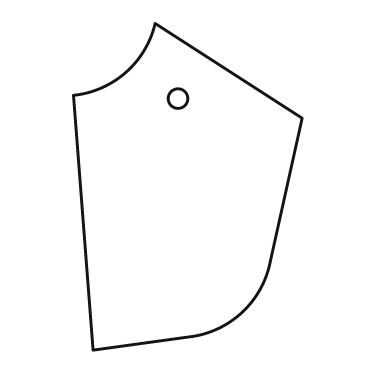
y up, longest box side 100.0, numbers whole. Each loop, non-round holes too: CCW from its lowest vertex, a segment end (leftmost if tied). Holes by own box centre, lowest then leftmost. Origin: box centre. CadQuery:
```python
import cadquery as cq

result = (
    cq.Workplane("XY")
    .moveTo(-29.0, -50.0)
    .lineTo(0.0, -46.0)
    .threePointArc((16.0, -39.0), (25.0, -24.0))
    .lineTo(35.0, 21.0)
    .lineTo(-10.0, 50.0)
    .threePointArc((-19.0, 35.0), (-35.0, 28.0))
    .close()
    .moveTo(-3.0, 27.0)
    .circle(3.0)
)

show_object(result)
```